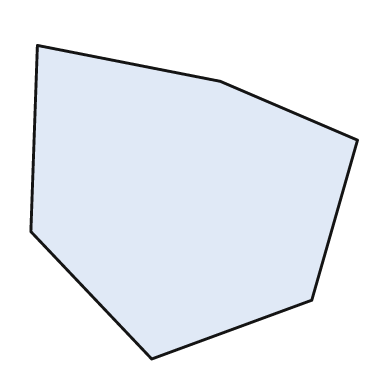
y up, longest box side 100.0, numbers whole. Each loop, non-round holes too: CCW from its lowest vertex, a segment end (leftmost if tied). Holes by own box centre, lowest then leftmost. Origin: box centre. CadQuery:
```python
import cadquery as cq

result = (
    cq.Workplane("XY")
    .moveTo(-13.0, -48.0)
    .lineTo(36.0, -30.0)
    .lineTo(50.0, 19.0)
    .lineTo(8.0, 37.0)
    .lineTo(-48.0, 48.0)
    .lineTo(-50.0, -9.0)
    .close()
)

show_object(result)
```